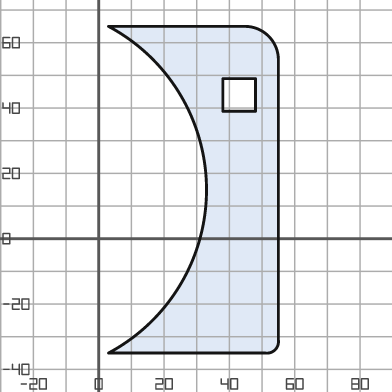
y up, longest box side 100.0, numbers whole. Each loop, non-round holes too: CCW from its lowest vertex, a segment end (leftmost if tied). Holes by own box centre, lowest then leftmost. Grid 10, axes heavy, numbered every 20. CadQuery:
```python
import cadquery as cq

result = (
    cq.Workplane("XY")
    .moveTo(3.0, -35.0)
    .lineTo(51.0, -35.0)
    .threePointArc((54.0, -34.0), (55.0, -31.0))
    .lineTo(55.0, 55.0)
    .threePointArc((52.0, 62.0), (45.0, 65.0))
    .lineTo(3.0, 65.0)
    .threePointArc((33.0, 15.0), (3.0, -35.0))
    .close()
    .moveTo(38.0, 39.0)
    .lineTo(48.0, 39.0)
    .lineTo(48.0, 49.0)
    .lineTo(38.0, 49.0)
    .close()
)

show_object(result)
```